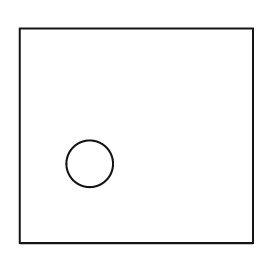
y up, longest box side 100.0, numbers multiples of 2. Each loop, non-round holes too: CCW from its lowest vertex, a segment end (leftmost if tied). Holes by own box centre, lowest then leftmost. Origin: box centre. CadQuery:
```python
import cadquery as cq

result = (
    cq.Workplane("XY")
    .moveTo(-50.0, -46.0)
    .lineTo(50.0, -46.0)
    .lineTo(50.0, 46.0)
    .lineTo(-50.0, 46.0)
    .close()
    .moveTo(-20.0, -12.0)
    .circle(10.0)
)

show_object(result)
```